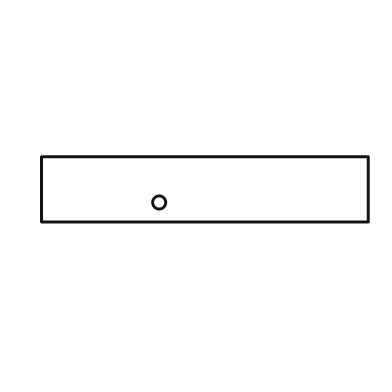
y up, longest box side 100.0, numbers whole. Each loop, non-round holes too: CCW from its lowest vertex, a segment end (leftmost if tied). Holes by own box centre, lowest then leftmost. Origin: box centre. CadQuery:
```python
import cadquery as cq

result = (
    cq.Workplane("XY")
    .moveTo(-50.0, -10.0)
    .lineTo(50.0, -10.0)
    .lineTo(50.0, 10.0)
    .lineTo(-50.0, 10.0)
    .close()
    .moveTo(-14.0, -4.0)
    .circle(2.0)
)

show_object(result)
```